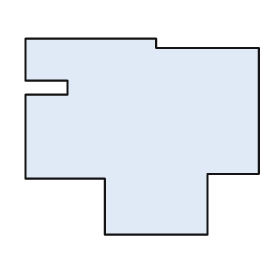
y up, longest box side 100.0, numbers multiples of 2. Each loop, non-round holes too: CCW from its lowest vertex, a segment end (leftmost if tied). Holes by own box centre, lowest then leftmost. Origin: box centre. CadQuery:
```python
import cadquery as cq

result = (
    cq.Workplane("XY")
    .moveTo(-16.0, -42.0)
    .lineTo(28.0, -42.0)
    .lineTo(28.0, -16.0)
    .lineTo(50.0, -16.0)
    .lineTo(50.0, 38.0)
    .lineTo(6.0, 38.0)
    .lineTo(6.0, 42.0)
    .lineTo(-50.0, 42.0)
    .lineTo(-50.0, 24.0)
    .lineTo(-32.0, 24.0)
    .lineTo(-32.0, 18.0)
    .lineTo(-50.0, 18.0)
    .lineTo(-50.0, -18.0)
    .lineTo(-16.0, -18.0)
    .close()
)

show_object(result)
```